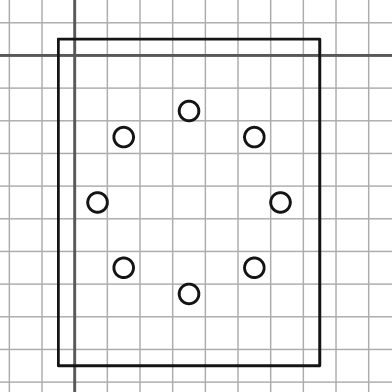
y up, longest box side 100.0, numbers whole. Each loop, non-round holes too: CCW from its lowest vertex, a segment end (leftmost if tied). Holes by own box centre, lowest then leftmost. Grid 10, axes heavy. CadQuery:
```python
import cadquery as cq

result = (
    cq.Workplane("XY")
    .moveTo(-5.0, -95.0)
    .lineTo(75.0, -95.0)
    .lineTo(75.0, 5.0)
    .lineTo(-5.0, 5.0)
    .close()
    .moveTo(35.0, -73.0)
    .circle(3.0)
    .moveTo(15.0, -65.0)
    .circle(3.0)
    .moveTo(55.0, -65.0)
    .circle(3.0)
    .moveTo(7.0, -45.0)
    .circle(3.0)
    .moveTo(63.0, -45.0)
    .circle(3.0)
    .moveTo(15.0, -25.0)
    .circle(3.0)
    .moveTo(55.0, -25.0)
    .circle(3.0)
    .moveTo(35.0, -17.0)
    .circle(3.0)
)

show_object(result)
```